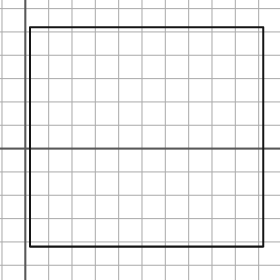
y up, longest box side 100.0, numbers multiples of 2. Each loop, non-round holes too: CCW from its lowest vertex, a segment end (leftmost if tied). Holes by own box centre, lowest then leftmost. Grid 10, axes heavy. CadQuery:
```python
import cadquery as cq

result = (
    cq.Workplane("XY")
    .moveTo(2.0, -42.0)
    .lineTo(102.0, -42.0)
    .lineTo(102.0, 52.0)
    .lineTo(2.0, 52.0)
    .close()
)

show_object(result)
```